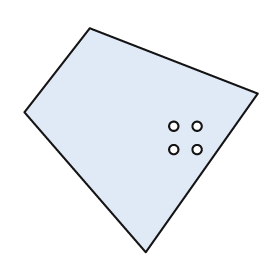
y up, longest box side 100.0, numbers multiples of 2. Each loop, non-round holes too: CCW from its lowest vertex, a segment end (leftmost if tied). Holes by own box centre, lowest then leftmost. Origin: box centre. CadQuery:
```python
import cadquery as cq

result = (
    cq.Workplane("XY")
    .moveTo(2.0, -48.0)
    .lineTo(50.0, 20.0)
    .lineTo(-22.0, 48.0)
    .lineTo(-50.0, 12.0)
    .close()
    .moveTo(14.0, -4.0)
    .circle(2.0)
    .moveTo(24.0, -4.0)
    .circle(2.0)
    .moveTo(14.0, 6.0)
    .circle(2.0)
    .moveTo(24.0, 6.0)
    .circle(2.0)
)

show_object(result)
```